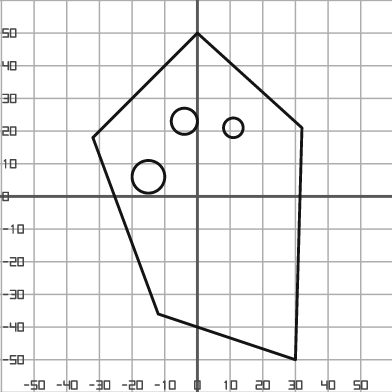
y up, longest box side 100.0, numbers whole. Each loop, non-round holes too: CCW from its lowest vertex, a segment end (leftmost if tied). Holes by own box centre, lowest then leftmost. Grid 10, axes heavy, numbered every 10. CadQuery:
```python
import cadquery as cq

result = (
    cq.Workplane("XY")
    .moveTo(30.0, -50.0)
    .lineTo(32.0, 21.0)
    .lineTo(0.0, 50.0)
    .lineTo(-32.0, 18.0)
    .lineTo(-12.0, -36.0)
    .close()
    .moveTo(-15.0, 6.0)
    .circle(5.0)
    .moveTo(11.0, 21.0)
    .circle(3.0)
    .moveTo(-4.0, 23.0)
    .circle(4.0)
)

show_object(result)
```